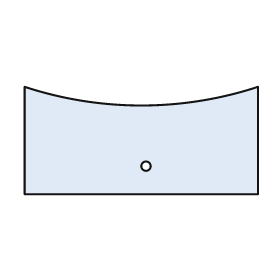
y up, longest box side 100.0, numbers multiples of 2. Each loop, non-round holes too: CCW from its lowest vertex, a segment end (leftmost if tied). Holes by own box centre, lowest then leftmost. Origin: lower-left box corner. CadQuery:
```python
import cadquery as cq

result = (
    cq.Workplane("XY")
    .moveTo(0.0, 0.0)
    .lineTo(100.0, 0.0)
    .lineTo(100.0, 46.0)
    .threePointArc((50.0, 38.0), (0.0, 46.0))
    .close()
    .moveTo(52.0, 12.0)
    .circle(2.0)
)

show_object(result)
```